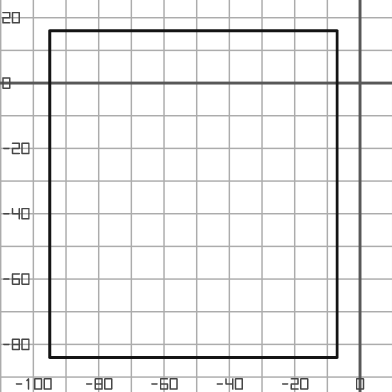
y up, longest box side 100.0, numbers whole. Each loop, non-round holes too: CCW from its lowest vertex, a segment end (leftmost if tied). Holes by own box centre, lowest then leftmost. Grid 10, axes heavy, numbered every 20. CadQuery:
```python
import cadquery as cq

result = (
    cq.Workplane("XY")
    .moveTo(-95.0, -84.0)
    .lineTo(-7.0, -84.0)
    .lineTo(-7.0, 16.0)
    .lineTo(-95.0, 16.0)
    .close()
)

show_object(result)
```